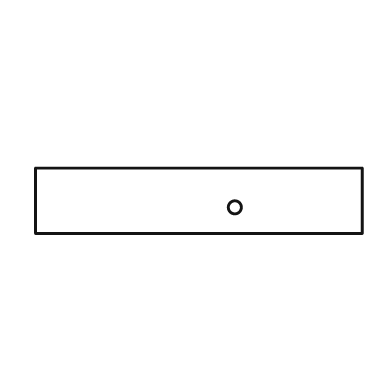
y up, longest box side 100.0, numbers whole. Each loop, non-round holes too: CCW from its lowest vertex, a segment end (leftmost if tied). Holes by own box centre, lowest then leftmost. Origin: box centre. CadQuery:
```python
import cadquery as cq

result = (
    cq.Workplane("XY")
    .moveTo(-50.0, -10.0)
    .lineTo(50.0, -10.0)
    .lineTo(50.0, 10.0)
    .lineTo(-50.0, 10.0)
    .close()
    .moveTo(11.0, -2.0)
    .circle(2.0)
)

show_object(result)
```